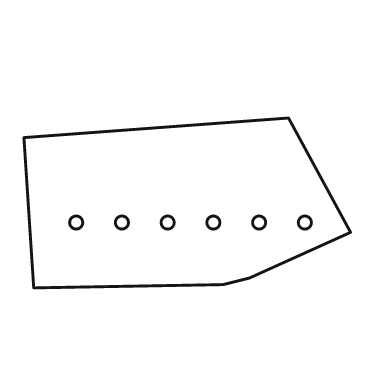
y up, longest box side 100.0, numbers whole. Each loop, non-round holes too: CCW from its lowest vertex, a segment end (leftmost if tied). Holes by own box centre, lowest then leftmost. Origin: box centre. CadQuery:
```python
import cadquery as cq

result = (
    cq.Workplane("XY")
    .moveTo(-47.0, -26.0)
    .lineTo(11.0, -25.0)
    .lineTo(19.0, -23.0)
    .lineTo(50.0, -9.0)
    .lineTo(31.0, 26.0)
    .lineTo(-50.0, 20.0)
    .close()
    .moveTo(-34.0, -6.0)
    .circle(2.0)
    .moveTo(-20.0, -6.0)
    .circle(2.0)
    .moveTo(-6.0, -6.0)
    .circle(2.0)
    .moveTo(8.0, -6.0)
    .circle(2.0)
    .moveTo(22.0, -6.0)
    .circle(2.0)
    .moveTo(36.0, -6.0)
    .circle(2.0)
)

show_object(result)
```